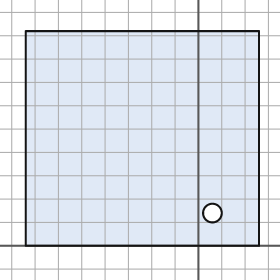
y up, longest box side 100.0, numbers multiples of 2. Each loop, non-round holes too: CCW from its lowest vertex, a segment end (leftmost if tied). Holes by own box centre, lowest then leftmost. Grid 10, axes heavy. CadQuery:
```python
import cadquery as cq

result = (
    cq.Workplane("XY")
    .moveTo(-74.0, 0.0)
    .lineTo(26.0, 0.0)
    .lineTo(26.0, 92.0)
    .lineTo(-74.0, 92.0)
    .close()
    .moveTo(6.0, 14.0)
    .circle(4.0)
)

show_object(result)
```